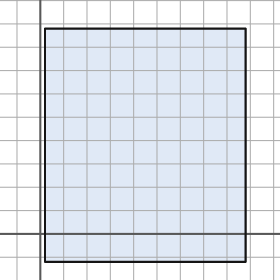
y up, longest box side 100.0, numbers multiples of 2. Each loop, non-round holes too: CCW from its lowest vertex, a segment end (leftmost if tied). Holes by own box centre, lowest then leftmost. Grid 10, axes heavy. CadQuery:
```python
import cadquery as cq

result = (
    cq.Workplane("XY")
    .moveTo(2.0, -12.0)
    .lineTo(88.0, -12.0)
    .lineTo(88.0, 88.0)
    .lineTo(2.0, 88.0)
    .close()
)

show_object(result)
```